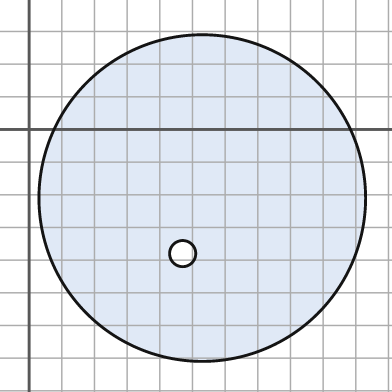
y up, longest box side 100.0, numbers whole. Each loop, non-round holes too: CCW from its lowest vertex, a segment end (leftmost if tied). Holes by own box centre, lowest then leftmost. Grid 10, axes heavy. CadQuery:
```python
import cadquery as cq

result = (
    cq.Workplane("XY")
    .moveTo(53.0, -21.0)
    .circle(50.0)
    .moveTo(47.0, -38.0)
    .circle(4.0)
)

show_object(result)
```